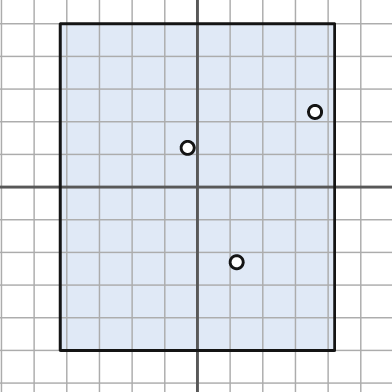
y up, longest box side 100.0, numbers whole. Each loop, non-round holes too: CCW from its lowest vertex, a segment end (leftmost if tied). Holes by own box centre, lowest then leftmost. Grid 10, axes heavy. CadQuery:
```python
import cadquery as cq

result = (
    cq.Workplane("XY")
    .moveTo(-42.0, -50.0)
    .lineTo(42.0, -50.0)
    .lineTo(42.0, 50.0)
    .lineTo(-42.0, 50.0)
    .close()
    .moveTo(12.0, -23.0)
    .circle(2.0)
    .moveTo(-3.0, 12.0)
    .circle(2.0)
    .moveTo(36.0, 23.0)
    .circle(2.0)
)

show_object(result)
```